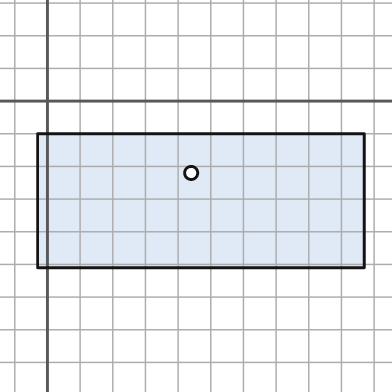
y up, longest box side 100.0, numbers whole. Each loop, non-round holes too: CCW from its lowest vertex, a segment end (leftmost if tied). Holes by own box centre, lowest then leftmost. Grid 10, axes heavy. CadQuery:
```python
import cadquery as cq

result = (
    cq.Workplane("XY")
    .moveTo(-3.0, -51.0)
    .lineTo(97.0, -51.0)
    .lineTo(97.0, -10.0)
    .lineTo(-3.0, -10.0)
    .close()
    .moveTo(44.0, -22.0)
    .circle(2.0)
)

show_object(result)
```